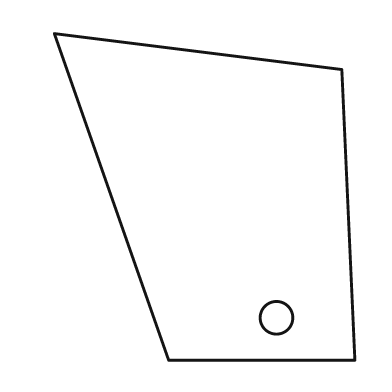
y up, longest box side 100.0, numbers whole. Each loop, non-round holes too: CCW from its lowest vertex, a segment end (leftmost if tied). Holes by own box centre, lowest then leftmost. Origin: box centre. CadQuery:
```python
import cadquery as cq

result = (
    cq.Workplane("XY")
    .moveTo(-11.0, -50.0)
    .lineTo(46.0, -50.0)
    .lineTo(42.0, 39.0)
    .lineTo(-46.0, 50.0)
    .close()
    .moveTo(22.0, -37.0)
    .circle(5.0)
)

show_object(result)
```